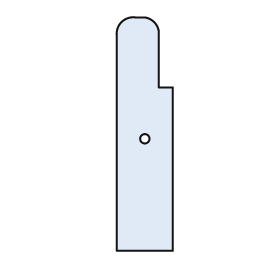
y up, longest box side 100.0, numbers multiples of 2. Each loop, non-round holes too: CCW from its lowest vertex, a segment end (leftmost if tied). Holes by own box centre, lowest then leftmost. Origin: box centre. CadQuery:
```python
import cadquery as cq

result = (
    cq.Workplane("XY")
    .moveTo(-12.0, -50.0)
    .lineTo(12.0, -50.0)
    .lineTo(12.0, 20.0)
    .lineTo(6.0, 20.0)
    .lineTo(6.0, 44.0)
    .threePointArc((4.0, 48.0), (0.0, 50.0))
    .lineTo(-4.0, 50.0)
    .threePointArc((-10.0, 48.0), (-12.0, 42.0))
    .close()
    .moveTo(0.0, -2.0)
    .circle(2.0)
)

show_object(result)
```